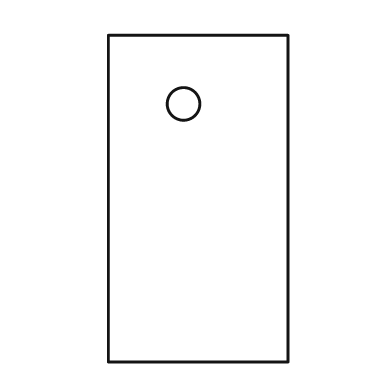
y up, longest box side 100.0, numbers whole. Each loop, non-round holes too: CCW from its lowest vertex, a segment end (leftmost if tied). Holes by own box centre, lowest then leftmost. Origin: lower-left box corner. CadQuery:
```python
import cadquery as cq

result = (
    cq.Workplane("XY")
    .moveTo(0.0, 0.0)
    .lineTo(55.0, 0.0)
    .lineTo(55.0, 100.0)
    .lineTo(0.0, 100.0)
    .close()
    .moveTo(23.0, 79.0)
    .circle(5.0)
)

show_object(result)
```